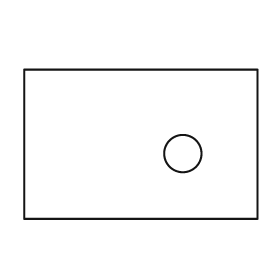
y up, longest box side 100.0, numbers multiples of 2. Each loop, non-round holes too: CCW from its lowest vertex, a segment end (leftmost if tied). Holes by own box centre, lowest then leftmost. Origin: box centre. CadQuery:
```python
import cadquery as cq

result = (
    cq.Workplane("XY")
    .moveTo(-50.0, -32.0)
    .lineTo(50.0, -32.0)
    .lineTo(50.0, 32.0)
    .lineTo(-50.0, 32.0)
    .close()
    .moveTo(18.0, -4.0)
    .circle(8.0)
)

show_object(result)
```